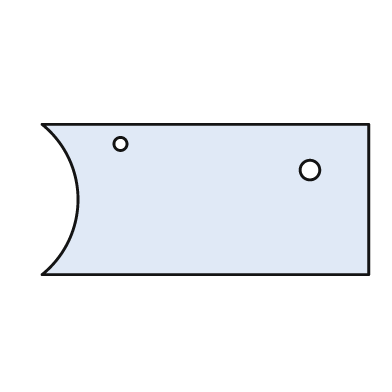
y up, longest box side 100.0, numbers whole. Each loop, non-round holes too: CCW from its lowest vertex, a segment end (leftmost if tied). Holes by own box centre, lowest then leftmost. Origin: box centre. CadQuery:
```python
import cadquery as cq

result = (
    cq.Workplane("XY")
    .moveTo(-50.0, -23.0)
    .lineTo(50.0, -23.0)
    .lineTo(50.0, 23.0)
    .lineTo(-50.0, 23.0)
    .threePointArc((-39.0, 0.0), (-50.0, -23.0))
    .close()
    .moveTo(32.0, 9.0)
    .circle(3.0)
    .moveTo(-26.0, 17.0)
    .circle(2.0)
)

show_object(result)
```